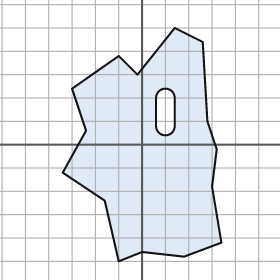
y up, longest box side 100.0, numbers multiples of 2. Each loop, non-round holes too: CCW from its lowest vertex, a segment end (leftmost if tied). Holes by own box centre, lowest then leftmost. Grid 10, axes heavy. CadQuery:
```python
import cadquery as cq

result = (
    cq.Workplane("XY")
    .moveTo(-10.0, -50.0)
    .lineTo(0.0, -46.0)
    .lineTo(18.0, -48.0)
    .lineTo(34.0, -42.0)
    .lineTo(30.0, -18.0)
    .lineTo(32.0, -2.0)
    .lineTo(28.0, 10.0)
    .lineTo(26.0, 44.0)
    .lineTo(14.0, 50.0)
    .lineTo(-2.0, 30.0)
    .lineTo(-10.0, 38.0)
    .lineTo(-30.0, 24.0)
    .lineTo(-24.0, 6.0)
    .lineTo(-34.0, -12.0)
    .lineTo(-16.0, -24.0)
    .close()
    .moveTo(6.0, 8.0)
    .threePointArc((10.0, 4.0), (14.0, 8.0))
    .lineTo(14.0, 20.0)
    .threePointArc((10.0, 24.0), (6.0, 20.0))
    .close()
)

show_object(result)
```